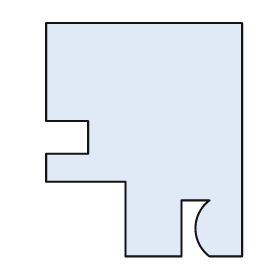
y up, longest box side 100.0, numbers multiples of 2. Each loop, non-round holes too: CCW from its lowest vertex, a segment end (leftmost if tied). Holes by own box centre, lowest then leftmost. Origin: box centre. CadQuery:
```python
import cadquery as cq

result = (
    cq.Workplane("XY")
    .moveTo(-8.0, -50.0)
    .lineTo(16.0, -50.0)
    .lineTo(16.0, -26.0)
    .lineTo(28.0, -26.0)
    .threePointArc((22.0, -38.0), (28.0, -50.0))
    .lineTo(42.0, -50.0)
    .lineTo(42.0, 50.0)
    .lineTo(-42.0, 50.0)
    .lineTo(-42.0, 8.0)
    .lineTo(-24.0, 8.0)
    .lineTo(-24.0, -6.0)
    .lineTo(-42.0, -6.0)
    .lineTo(-42.0, -18.0)
    .lineTo(-8.0, -18.0)
    .close()
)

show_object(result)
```